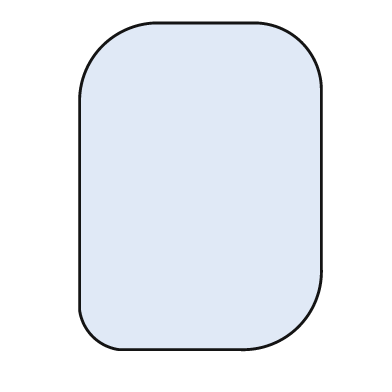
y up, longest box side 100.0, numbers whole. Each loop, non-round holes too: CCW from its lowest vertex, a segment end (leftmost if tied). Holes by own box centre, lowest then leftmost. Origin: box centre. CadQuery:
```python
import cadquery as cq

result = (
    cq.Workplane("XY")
    .moveTo(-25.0, -50.0)
    .lineTo(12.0, -50.0)
    .threePointArc((30.0, -43.0), (37.0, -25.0))
    .lineTo(37.0, 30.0)
    .threePointArc((31.0, 44.0), (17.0, 50.0))
    .lineTo(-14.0, 50.0)
    .threePointArc((-30.0, 43.0), (-37.0, 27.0))
    .lineTo(-37.0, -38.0)
    .threePointArc((-33.0, -46.0), (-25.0, -50.0))
    .close()
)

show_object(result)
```